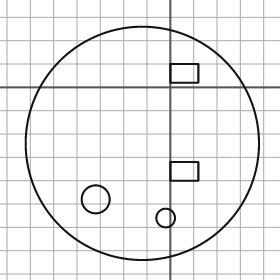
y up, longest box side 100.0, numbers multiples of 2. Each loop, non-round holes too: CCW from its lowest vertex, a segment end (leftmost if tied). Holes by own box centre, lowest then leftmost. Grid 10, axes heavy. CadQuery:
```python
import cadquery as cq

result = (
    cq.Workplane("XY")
    .moveTo(-12.0, -24.0)
    .circle(50.0)
    .moveTo(-2.0, -56.0)
    .circle(4.0)
    .moveTo(-32.0, -48.0)
    .circle(6.0)
    .moveTo(0.0, -40.0)
    .lineTo(12.0, -40.0)
    .lineTo(12.0, -32.0)
    .lineTo(0.0, -32.0)
    .close()
    .moveTo(0.0, 2.0)
    .lineTo(12.0, 2.0)
    .lineTo(12.0, 10.0)
    .lineTo(0.0, 10.0)
    .close()
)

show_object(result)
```